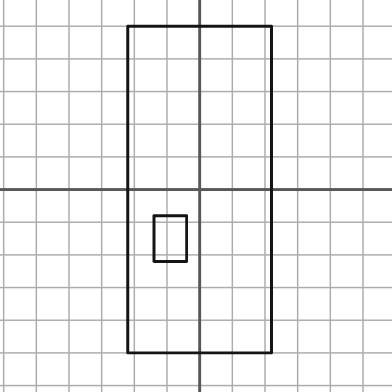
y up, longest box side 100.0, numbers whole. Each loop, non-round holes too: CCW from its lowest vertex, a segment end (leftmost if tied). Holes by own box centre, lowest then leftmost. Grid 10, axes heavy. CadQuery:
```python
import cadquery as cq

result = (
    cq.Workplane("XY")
    .moveTo(-22.0, -50.0)
    .lineTo(22.0, -50.0)
    .lineTo(22.0, 50.0)
    .lineTo(-22.0, 50.0)
    .close()
    .moveTo(-14.0, -22.0)
    .lineTo(-4.0, -22.0)
    .lineTo(-4.0, -8.0)
    .lineTo(-14.0, -8.0)
    .close()
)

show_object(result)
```